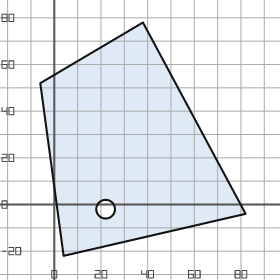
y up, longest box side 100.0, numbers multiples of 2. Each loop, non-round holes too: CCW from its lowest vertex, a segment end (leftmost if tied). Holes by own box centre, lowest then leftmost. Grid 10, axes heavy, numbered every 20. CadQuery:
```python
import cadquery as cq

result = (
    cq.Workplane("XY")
    .moveTo(4.0, -22.0)
    .lineTo(82.0, -4.0)
    .lineTo(38.0, 78.0)
    .lineTo(-6.0, 52.0)
    .close()
    .moveTo(22.0, -2.0)
    .circle(4.0)
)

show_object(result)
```